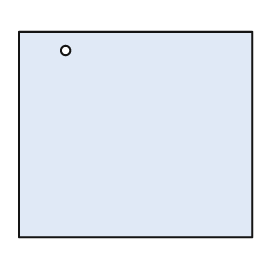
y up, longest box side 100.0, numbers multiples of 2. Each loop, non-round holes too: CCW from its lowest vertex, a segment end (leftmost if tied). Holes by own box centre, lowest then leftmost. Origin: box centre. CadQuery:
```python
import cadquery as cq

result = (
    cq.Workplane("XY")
    .moveTo(-50.0, -44.0)
    .lineTo(50.0, -44.0)
    .lineTo(50.0, 44.0)
    .lineTo(-50.0, 44.0)
    .close()
    .moveTo(-30.0, 36.0)
    .circle(2.0)
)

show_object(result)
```